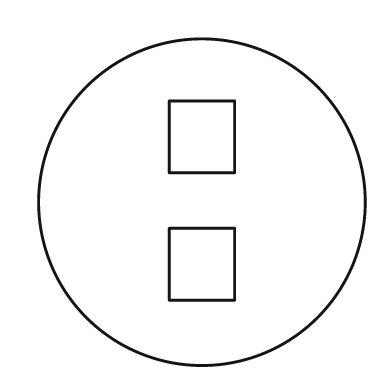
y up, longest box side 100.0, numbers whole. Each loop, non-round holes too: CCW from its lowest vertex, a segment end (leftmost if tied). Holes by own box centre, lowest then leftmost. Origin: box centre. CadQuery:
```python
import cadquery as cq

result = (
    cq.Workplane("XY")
    .moveTo(0.0, 0.0)
    .circle(50.0)
    .moveTo(-10.0, -30.0)
    .lineTo(10.0, -30.0)
    .lineTo(10.0, -8.0)
    .lineTo(-10.0, -8.0)
    .close()
    .moveTo(-10.0, 9.0)
    .lineTo(10.0, 9.0)
    .lineTo(10.0, 31.0)
    .lineTo(-10.0, 31.0)
    .close()
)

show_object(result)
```